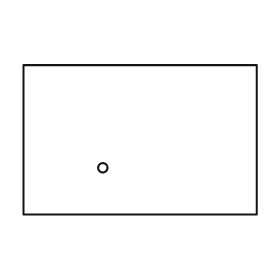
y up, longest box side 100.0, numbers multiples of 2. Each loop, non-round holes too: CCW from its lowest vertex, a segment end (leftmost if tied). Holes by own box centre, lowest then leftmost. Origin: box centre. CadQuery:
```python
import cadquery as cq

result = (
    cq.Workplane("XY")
    .moveTo(-50.0, -32.0)
    .lineTo(50.0, -32.0)
    .lineTo(50.0, 32.0)
    .lineTo(-50.0, 32.0)
    .close()
    .moveTo(-16.0, -12.0)
    .circle(2.0)
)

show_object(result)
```